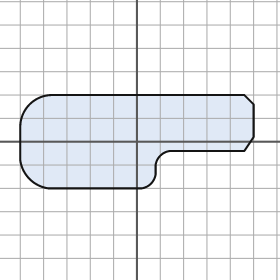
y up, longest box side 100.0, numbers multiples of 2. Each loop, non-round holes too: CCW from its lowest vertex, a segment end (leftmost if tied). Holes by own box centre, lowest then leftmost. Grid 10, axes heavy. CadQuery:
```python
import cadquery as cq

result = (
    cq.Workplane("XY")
    .moveTo(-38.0, -20.0)
    .lineTo(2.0, -20.0)
    .threePointArc((6.0, -18.0), (8.0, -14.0))
    .lineTo(8.0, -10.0)
    .threePointArc((10.0, -6.0), (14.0, -4.0))
    .lineTo(46.0, -4.0)
    .lineTo(50.0, 2.0)
    .lineTo(50.0, 16.0)
    .lineTo(46.0, 20.0)
    .lineTo(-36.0, 20.0)
    .threePointArc((-46.0, 16.0), (-50.0, 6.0))
    .lineTo(-50.0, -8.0)
    .threePointArc((-46.0, -16.0), (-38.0, -20.0))
    .close()
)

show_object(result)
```